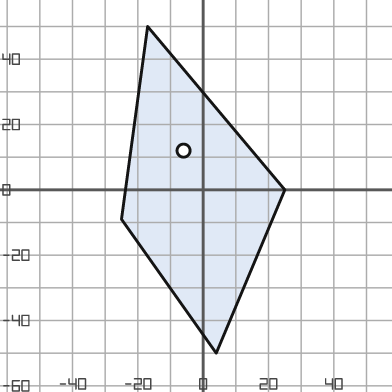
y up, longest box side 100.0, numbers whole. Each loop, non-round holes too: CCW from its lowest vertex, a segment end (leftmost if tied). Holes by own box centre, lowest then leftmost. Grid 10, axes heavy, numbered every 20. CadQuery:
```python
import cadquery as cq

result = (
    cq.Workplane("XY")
    .moveTo(4.0, -50.0)
    .lineTo(25.0, 0.0)
    .lineTo(-17.0, 50.0)
    .lineTo(-25.0, -9.0)
    .close()
    .moveTo(-6.0, 12.0)
    .circle(2.0)
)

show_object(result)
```